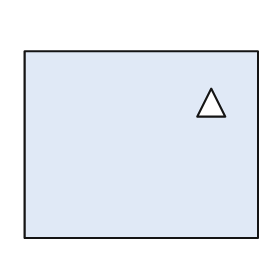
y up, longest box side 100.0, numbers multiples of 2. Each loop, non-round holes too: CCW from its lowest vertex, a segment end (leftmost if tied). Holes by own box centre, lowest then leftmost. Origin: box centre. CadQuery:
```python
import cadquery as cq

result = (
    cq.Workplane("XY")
    .moveTo(-50.0, -40.0)
    .lineTo(50.0, -40.0)
    .lineTo(50.0, 40.0)
    .lineTo(-50.0, 40.0)
    .close()
    .moveTo(24.0, 12.0)
    .lineTo(36.0, 12.0)
    .lineTo(30.0, 24.0)
    .close()
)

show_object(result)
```